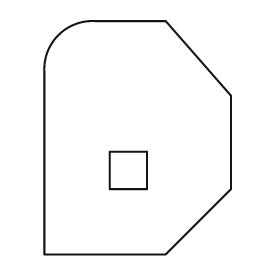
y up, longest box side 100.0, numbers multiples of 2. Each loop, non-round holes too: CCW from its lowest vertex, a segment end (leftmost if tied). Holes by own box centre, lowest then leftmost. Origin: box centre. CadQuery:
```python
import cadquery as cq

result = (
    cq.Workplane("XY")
    .moveTo(-40.0, -50.0)
    .lineTo(12.0, -50.0)
    .lineTo(40.0, -22.0)
    .lineTo(40.0, 18.0)
    .lineTo(12.0, 50.0)
    .lineTo(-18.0, 50.0)
    .threePointArc((-34.0, 44.0), (-40.0, 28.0))
    .close()
    .moveTo(-12.0, -22.0)
    .lineTo(4.0, -22.0)
    .lineTo(4.0, -6.0)
    .lineTo(-12.0, -6.0)
    .close()
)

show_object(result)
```